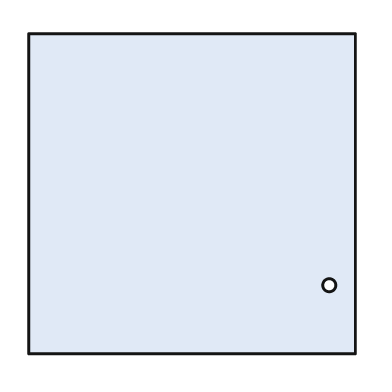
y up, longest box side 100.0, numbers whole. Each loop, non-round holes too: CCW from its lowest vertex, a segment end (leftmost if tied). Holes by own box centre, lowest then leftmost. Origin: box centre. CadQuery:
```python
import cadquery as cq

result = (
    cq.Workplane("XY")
    .moveTo(-50.0, -49.0)
    .lineTo(50.0, -49.0)
    .lineTo(50.0, 49.0)
    .lineTo(-50.0, 49.0)
    .close()
    .moveTo(42.0, -28.0)
    .circle(2.0)
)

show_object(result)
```